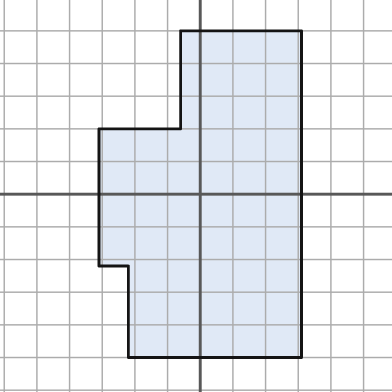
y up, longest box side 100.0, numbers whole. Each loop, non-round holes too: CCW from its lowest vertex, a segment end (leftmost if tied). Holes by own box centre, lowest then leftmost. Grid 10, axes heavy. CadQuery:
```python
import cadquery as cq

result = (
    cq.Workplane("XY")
    .moveTo(-22.0, -50.0)
    .lineTo(31.0, -50.0)
    .lineTo(31.0, 50.0)
    .lineTo(-6.0, 50.0)
    .lineTo(-6.0, 20.0)
    .lineTo(-31.0, 20.0)
    .lineTo(-31.0, -22.0)
    .lineTo(-22.0, -22.0)
    .close()
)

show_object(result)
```